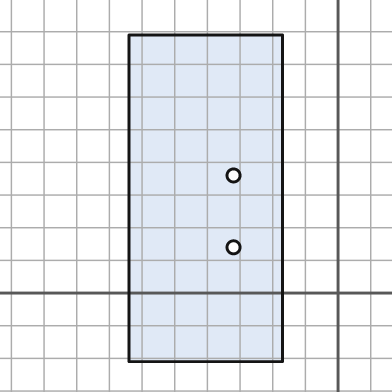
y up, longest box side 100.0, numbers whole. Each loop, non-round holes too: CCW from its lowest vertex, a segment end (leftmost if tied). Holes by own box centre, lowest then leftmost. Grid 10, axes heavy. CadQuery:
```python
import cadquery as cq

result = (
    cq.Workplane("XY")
    .moveTo(-64.0, -21.0)
    .lineTo(-17.0, -21.0)
    .lineTo(-17.0, 79.0)
    .lineTo(-64.0, 79.0)
    .close()
    .moveTo(-32.0, 14.0)
    .circle(2.0)
    .moveTo(-32.0, 36.0)
    .circle(2.0)
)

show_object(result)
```